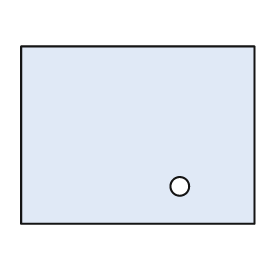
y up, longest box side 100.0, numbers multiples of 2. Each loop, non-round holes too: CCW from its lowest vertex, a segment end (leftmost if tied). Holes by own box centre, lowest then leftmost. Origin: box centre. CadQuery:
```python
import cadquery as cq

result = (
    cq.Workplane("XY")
    .moveTo(-50.0, -38.0)
    .lineTo(50.0, -38.0)
    .lineTo(50.0, 38.0)
    .lineTo(-50.0, 38.0)
    .close()
    .moveTo(18.0, -22.0)
    .circle(4.0)
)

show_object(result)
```